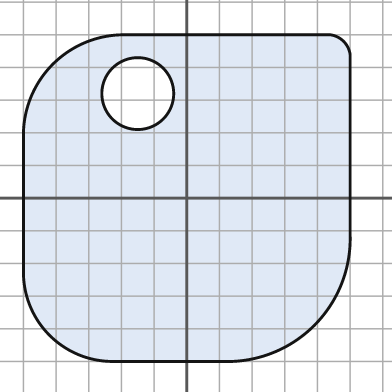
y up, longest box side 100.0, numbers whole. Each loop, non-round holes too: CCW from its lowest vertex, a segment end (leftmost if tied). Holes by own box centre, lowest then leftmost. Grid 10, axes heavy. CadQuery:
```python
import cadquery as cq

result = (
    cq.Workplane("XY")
    .moveTo(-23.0, -50.0)
    .lineTo(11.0, -50.0)
    .threePointArc((39.0, -39.0), (50.0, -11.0))
    .lineTo(50.0, 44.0)
    .threePointArc((48.0, 48.0), (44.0, 50.0))
    .lineTo(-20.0, 50.0)
    .threePointArc((-41.0, 41.0), (-50.0, 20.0))
    .lineTo(-50.0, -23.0)
    .threePointArc((-42.0, -42.0), (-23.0, -50.0))
    .close()
    .moveTo(-15.0, 32.0)
    .circle(11.0)
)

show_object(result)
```